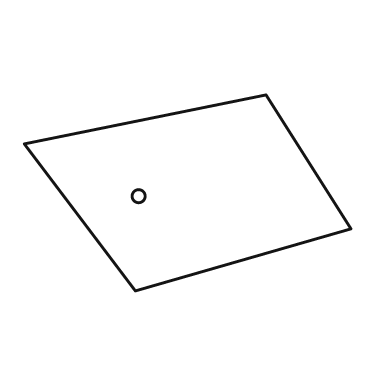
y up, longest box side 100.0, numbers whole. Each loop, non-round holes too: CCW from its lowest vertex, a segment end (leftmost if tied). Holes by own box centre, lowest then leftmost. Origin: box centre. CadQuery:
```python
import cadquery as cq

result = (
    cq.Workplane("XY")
    .moveTo(-16.0, -30.0)
    .lineTo(50.0, -11.0)
    .lineTo(24.0, 30.0)
    .lineTo(-50.0, 15.0)
    .close()
    .moveTo(-15.0, -1.0)
    .circle(2.0)
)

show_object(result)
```